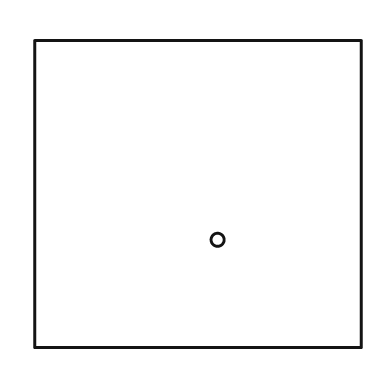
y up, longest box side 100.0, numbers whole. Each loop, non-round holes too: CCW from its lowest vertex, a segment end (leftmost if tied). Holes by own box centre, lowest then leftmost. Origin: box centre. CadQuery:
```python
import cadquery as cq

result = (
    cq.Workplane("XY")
    .moveTo(-50.0, -47.0)
    .lineTo(50.0, -47.0)
    .lineTo(50.0, 47.0)
    .lineTo(-50.0, 47.0)
    .close()
    .moveTo(6.0, -14.0)
    .circle(2.0)
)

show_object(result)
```